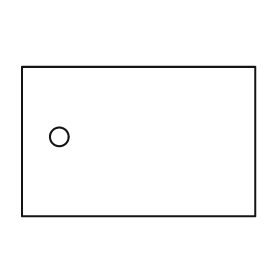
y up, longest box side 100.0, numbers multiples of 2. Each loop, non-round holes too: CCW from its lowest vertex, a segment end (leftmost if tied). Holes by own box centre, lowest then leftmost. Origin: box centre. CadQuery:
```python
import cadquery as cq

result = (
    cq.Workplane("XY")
    .moveTo(-50.0, -32.0)
    .lineTo(50.0, -32.0)
    .lineTo(50.0, 32.0)
    .lineTo(-50.0, 32.0)
    .close()
    .moveTo(-34.0, 2.0)
    .circle(4.0)
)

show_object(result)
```